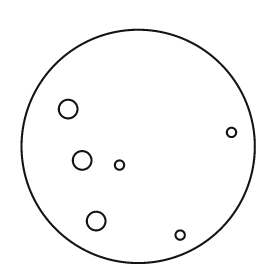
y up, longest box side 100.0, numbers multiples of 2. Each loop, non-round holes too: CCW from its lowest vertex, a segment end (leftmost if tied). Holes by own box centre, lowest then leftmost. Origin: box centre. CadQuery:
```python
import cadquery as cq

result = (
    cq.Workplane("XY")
    .moveTo(0.0, 0.0)
    .circle(50.0)
    .moveTo(18.0, -38.0)
    .circle(2.0)
    .moveTo(-18.0, -32.0)
    .circle(4.0)
    .moveTo(-8.0, -8.0)
    .circle(2.0)
    .moveTo(-24.0, -6.0)
    .circle(4.0)
    .moveTo(40.0, 6.0)
    .circle(2.0)
    .moveTo(-30.0, 16.0)
    .circle(4.0)
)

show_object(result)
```